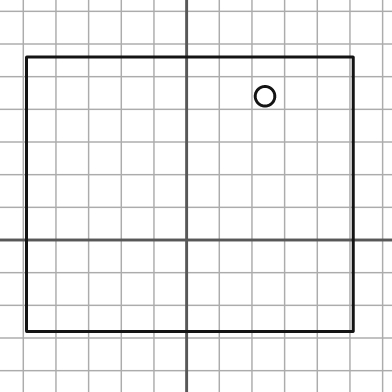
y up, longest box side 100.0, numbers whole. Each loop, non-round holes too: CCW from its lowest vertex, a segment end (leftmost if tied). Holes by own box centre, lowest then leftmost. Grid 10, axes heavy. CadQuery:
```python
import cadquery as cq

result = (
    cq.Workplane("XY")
    .moveTo(-49.0, -28.0)
    .lineTo(51.0, -28.0)
    .lineTo(51.0, 56.0)
    .lineTo(-49.0, 56.0)
    .close()
    .moveTo(24.0, 44.0)
    .circle(3.0)
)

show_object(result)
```